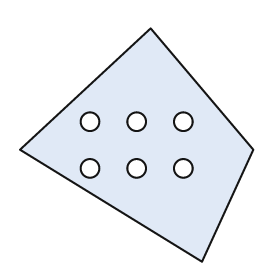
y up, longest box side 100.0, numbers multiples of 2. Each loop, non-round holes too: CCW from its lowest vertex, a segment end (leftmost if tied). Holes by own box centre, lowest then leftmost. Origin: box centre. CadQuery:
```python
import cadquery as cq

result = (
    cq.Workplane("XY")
    .moveTo(28.0, -50.0)
    .lineTo(50.0, -2.0)
    .lineTo(6.0, 50.0)
    .lineTo(-50.0, -2.0)
    .close()
    .moveTo(-20.0, -10.0)
    .circle(4.0)
    .moveTo(0.0, -10.0)
    .circle(4.0)
    .moveTo(20.0, -10.0)
    .circle(4.0)
    .moveTo(-20.0, 10.0)
    .circle(4.0)
    .moveTo(0.0, 10.0)
    .circle(4.0)
    .moveTo(20.0, 10.0)
    .circle(4.0)
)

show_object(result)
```